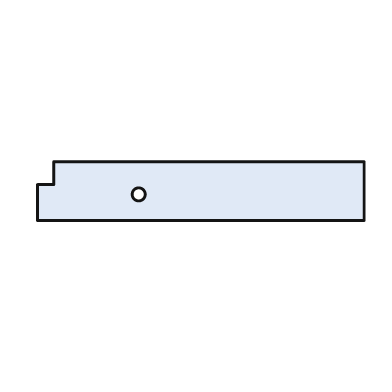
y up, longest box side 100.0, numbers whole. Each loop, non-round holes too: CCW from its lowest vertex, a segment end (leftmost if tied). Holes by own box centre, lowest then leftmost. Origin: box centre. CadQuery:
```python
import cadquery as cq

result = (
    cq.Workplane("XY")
    .moveTo(-50.0, -9.0)
    .lineTo(50.0, -9.0)
    .lineTo(50.0, 9.0)
    .lineTo(-45.0, 9.0)
    .lineTo(-45.0, 2.0)
    .lineTo(-50.0, 2.0)
    .close()
    .moveTo(-19.0, -1.0)
    .circle(2.0)
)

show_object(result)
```